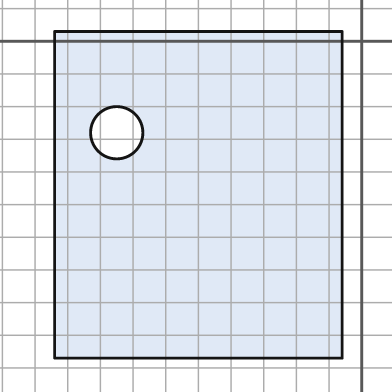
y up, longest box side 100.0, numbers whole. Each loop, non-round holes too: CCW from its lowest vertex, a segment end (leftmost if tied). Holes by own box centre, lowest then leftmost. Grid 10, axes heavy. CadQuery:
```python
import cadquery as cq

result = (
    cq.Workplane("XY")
    .moveTo(-94.0, -97.0)
    .lineTo(-6.0, -97.0)
    .lineTo(-6.0, 3.0)
    .lineTo(-94.0, 3.0)
    .close()
    .moveTo(-75.0, -28.0)
    .circle(8.0)
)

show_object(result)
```